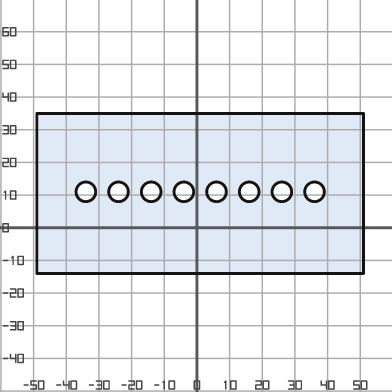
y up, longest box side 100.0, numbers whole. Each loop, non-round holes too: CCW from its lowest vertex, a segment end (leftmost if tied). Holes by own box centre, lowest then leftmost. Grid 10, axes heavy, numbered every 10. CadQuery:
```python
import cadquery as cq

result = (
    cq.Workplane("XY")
    .moveTo(-49.0, -14.0)
    .lineTo(51.0, -14.0)
    .lineTo(51.0, 35.0)
    .lineTo(-49.0, 35.0)
    .close()
    .moveTo(-34.0, 11.0)
    .circle(3.0)
    .moveTo(-24.0, 11.0)
    .circle(3.0)
    .moveTo(-14.0, 11.0)
    .circle(3.0)
    .moveTo(-4.0, 11.0)
    .circle(3.0)
    .moveTo(6.0, 11.0)
    .circle(3.0)
    .moveTo(16.0, 11.0)
    .circle(3.0)
    .moveTo(26.0, 11.0)
    .circle(3.0)
    .moveTo(36.0, 11.0)
    .circle(3.0)
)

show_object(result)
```